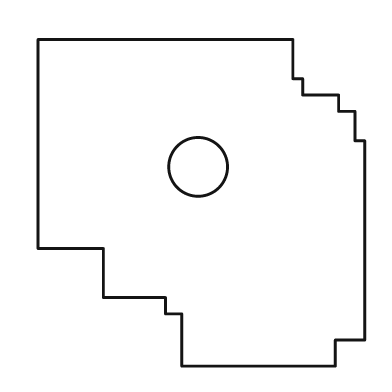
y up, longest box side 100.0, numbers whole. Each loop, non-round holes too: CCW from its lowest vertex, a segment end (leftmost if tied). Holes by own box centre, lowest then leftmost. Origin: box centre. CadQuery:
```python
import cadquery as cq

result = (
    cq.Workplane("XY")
    .moveTo(-6.0, -50.0)
    .lineTo(41.0, -50.0)
    .lineTo(41.0, -42.0)
    .lineTo(50.0, -42.0)
    .lineTo(50.0, 19.0)
    .lineTo(47.0, 19.0)
    .lineTo(47.0, 28.0)
    .lineTo(42.0, 28.0)
    .lineTo(42.0, 33.0)
    .lineTo(31.0, 33.0)
    .lineTo(31.0, 38.0)
    .lineTo(28.0, 38.0)
    .lineTo(28.0, 50.0)
    .lineTo(-50.0, 50.0)
    .lineTo(-50.0, -14.0)
    .lineTo(-30.0, -14.0)
    .lineTo(-30.0, -29.0)
    .lineTo(-11.0, -29.0)
    .lineTo(-11.0, -34.0)
    .lineTo(-6.0, -34.0)
    .close()
    .moveTo(-1.0, 11.0)
    .circle(9.0)
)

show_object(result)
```